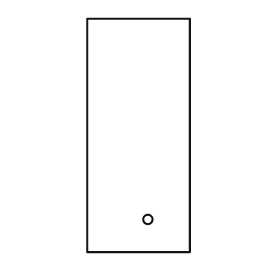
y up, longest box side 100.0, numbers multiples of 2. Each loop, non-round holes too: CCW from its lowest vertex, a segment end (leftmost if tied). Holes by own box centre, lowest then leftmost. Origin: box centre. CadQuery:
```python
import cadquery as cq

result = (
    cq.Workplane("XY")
    .moveTo(-22.0, -50.0)
    .lineTo(22.0, -50.0)
    .lineTo(22.0, 50.0)
    .lineTo(-22.0, 50.0)
    .close()
    .moveTo(4.0, -36.0)
    .circle(2.0)
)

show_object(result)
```